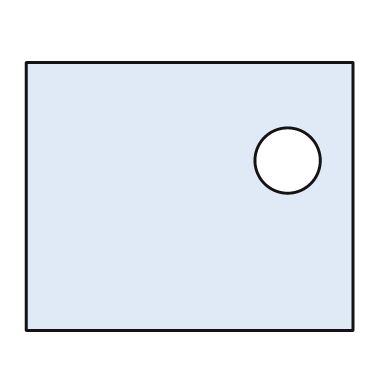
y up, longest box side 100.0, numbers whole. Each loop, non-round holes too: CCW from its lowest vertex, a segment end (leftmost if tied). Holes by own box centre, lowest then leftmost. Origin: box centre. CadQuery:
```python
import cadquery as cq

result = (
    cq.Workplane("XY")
    .moveTo(-50.0, -41.0)
    .lineTo(50.0, -41.0)
    .lineTo(50.0, 41.0)
    .lineTo(-50.0, 41.0)
    .close()
    .moveTo(30.0, 11.0)
    .circle(10.0)
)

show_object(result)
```